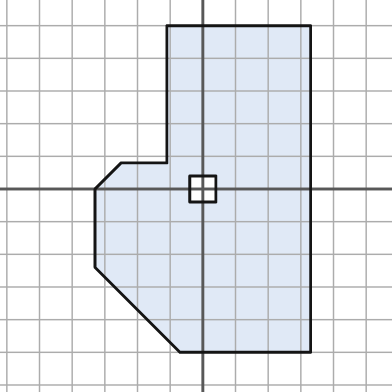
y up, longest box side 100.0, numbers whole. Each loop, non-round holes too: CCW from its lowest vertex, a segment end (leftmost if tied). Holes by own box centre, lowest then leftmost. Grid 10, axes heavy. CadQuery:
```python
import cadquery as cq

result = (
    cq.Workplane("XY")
    .moveTo(-7.0, -50.0)
    .lineTo(33.0, -50.0)
    .lineTo(33.0, 50.0)
    .lineTo(-11.0, 50.0)
    .lineTo(-11.0, 8.0)
    .lineTo(-25.0, 8.0)
    .lineTo(-33.0, 0.0)
    .lineTo(-33.0, -24.0)
    .close()
    .moveTo(-4.0, -4.0)
    .lineTo(4.0, -4.0)
    .lineTo(4.0, 4.0)
    .lineTo(-4.0, 4.0)
    .close()
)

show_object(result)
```